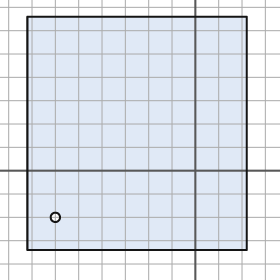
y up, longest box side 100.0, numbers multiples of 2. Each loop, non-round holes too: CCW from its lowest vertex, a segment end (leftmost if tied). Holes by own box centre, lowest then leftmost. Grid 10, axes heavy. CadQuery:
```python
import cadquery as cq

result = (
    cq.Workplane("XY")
    .moveTo(-72.0, -34.0)
    .lineTo(22.0, -34.0)
    .lineTo(22.0, 66.0)
    .lineTo(-72.0, 66.0)
    .close()
    .moveTo(-60.0, -20.0)
    .circle(2.0)
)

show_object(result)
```